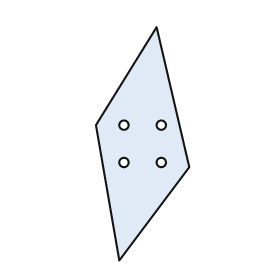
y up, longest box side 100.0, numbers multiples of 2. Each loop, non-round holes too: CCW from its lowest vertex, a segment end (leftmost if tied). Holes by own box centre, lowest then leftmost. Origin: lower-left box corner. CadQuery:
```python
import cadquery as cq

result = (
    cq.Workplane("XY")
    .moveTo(10.0, 0.0)
    .lineTo(40.0, 40.0)
    .lineTo(26.0, 100.0)
    .lineTo(0.0, 58.0)
    .close()
    .moveTo(12.0, 42.0)
    .circle(2.0)
    .moveTo(28.0, 42.0)
    .circle(2.0)
    .moveTo(12.0, 58.0)
    .circle(2.0)
    .moveTo(28.0, 58.0)
    .circle(2.0)
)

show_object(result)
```